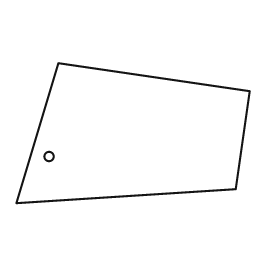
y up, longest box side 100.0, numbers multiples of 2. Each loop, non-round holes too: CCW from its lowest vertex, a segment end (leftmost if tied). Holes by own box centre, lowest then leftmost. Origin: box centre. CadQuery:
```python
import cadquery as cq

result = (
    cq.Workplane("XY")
    .moveTo(-50.0, -30.0)
    .lineTo(44.0, -24.0)
    .lineTo(50.0, 18.0)
    .lineTo(-32.0, 30.0)
    .close()
    .moveTo(-36.0, -10.0)
    .circle(2.0)
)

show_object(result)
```